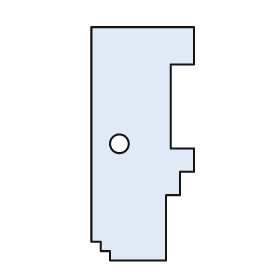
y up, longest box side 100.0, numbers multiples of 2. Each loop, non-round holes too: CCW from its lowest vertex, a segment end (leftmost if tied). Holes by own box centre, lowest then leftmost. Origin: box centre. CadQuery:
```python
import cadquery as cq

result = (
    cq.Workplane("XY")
    .moveTo(-14.0, -50.0)
    .lineTo(10.0, -50.0)
    .lineTo(10.0, -22.0)
    .lineTo(16.0, -22.0)
    .lineTo(16.0, -12.0)
    .lineTo(22.0, -12.0)
    .lineTo(22.0, -2.0)
    .lineTo(12.0, -2.0)
    .lineTo(12.0, 34.0)
    .lineTo(22.0, 34.0)
    .lineTo(22.0, 50.0)
    .lineTo(-22.0, 50.0)
    .lineTo(-22.0, -42.0)
    .lineTo(-18.0, -42.0)
    .lineTo(-18.0, -46.0)
    .lineTo(-14.0, -46.0)
    .close()
    .moveTo(-10.0, 0.0)
    .circle(4.0)
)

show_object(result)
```